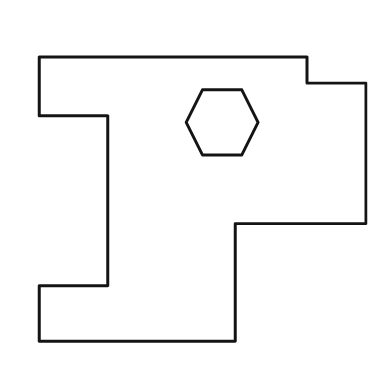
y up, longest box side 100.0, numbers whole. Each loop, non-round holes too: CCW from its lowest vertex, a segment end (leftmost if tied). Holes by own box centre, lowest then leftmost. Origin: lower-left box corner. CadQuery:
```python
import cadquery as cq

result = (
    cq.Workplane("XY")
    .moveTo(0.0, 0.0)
    .lineTo(60.0, 0.0)
    .lineTo(60.0, 36.0)
    .lineTo(100.0, 36.0)
    .lineTo(100.0, 79.0)
    .lineTo(82.0, 79.0)
    .lineTo(82.0, 87.0)
    .lineTo(0.0, 87.0)
    .lineTo(0.0, 69.0)
    .lineTo(21.0, 69.0)
    .lineTo(21.0, 17.0)
    .lineTo(0.0, 17.0)
    .close()
    .moveTo(50.0, 57.0)
    .lineTo(62.0, 57.0)
    .lineTo(67.0, 67.0)
    .lineTo(62.0, 77.0)
    .lineTo(50.0, 77.0)
    .lineTo(45.0, 67.0)
    .close()
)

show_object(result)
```